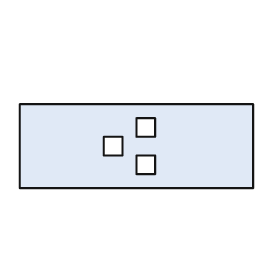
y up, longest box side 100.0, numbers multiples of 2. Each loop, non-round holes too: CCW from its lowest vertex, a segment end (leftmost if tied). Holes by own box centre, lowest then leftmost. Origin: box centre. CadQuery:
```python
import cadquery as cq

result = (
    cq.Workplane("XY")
    .moveTo(-50.0, -18.0)
    .lineTo(50.0, -18.0)
    .lineTo(50.0, 18.0)
    .lineTo(-50.0, 18.0)
    .close()
    .moveTo(0.0, -12.0)
    .lineTo(8.0, -12.0)
    .lineTo(8.0, -4.0)
    .lineTo(0.0, -4.0)
    .close()
    .moveTo(-14.0, -4.0)
    .lineTo(-6.0, -4.0)
    .lineTo(-6.0, 4.0)
    .lineTo(-14.0, 4.0)
    .close()
    .moveTo(0.0, 4.0)
    .lineTo(8.0, 4.0)
    .lineTo(8.0, 12.0)
    .lineTo(0.0, 12.0)
    .close()
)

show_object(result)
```